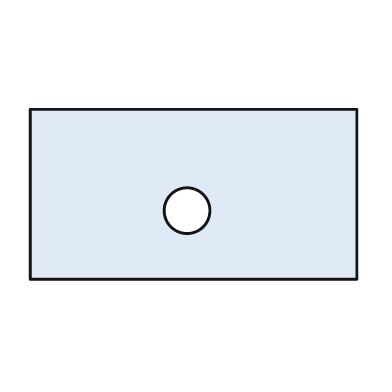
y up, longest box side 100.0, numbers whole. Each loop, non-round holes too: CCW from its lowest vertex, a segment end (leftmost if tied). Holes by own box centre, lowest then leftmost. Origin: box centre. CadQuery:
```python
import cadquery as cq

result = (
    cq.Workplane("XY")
    .moveTo(-50.0, -26.0)
    .lineTo(50.0, -26.0)
    .lineTo(50.0, 26.0)
    .lineTo(-50.0, 26.0)
    .close()
    .moveTo(-2.0, -5.0)
    .circle(7.0)
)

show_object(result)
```